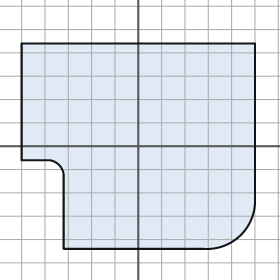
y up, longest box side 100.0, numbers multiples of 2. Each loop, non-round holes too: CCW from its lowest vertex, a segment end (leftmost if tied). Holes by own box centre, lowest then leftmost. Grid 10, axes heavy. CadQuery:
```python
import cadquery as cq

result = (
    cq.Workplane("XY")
    .moveTo(-32.0, -44.0)
    .lineTo(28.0, -44.0)
    .threePointArc((44.0, -38.0), (50.0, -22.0))
    .lineTo(50.0, 44.0)
    .lineTo(-50.0, 44.0)
    .lineTo(-50.0, -6.0)
    .lineTo(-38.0, -6.0)
    .threePointArc((-34.0, -8.0), (-32.0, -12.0))
    .close()
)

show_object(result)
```